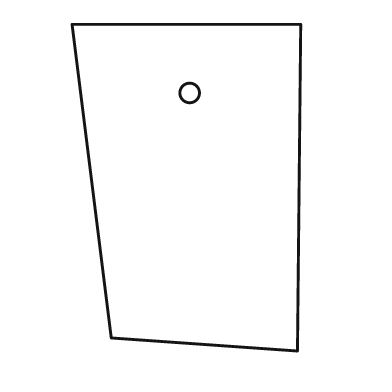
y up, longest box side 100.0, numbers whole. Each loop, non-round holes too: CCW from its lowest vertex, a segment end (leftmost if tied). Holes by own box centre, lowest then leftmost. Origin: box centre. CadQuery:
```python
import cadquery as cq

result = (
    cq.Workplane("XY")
    .moveTo(34.0, -50.0)
    .lineTo(35.0, 50.0)
    .lineTo(-35.0, 50.0)
    .lineTo(-23.0, -46.0)
    .close()
    .moveTo(1.0, 29.0)
    .circle(3.0)
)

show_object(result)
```